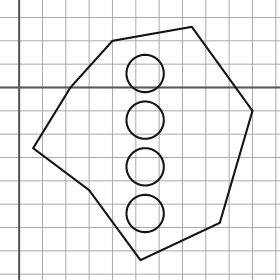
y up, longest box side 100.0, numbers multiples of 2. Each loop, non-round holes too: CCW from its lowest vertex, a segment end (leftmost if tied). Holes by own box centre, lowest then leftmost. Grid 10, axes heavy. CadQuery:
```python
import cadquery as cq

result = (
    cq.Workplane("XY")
    .moveTo(52.0, -74.0)
    .lineTo(86.0, -58.0)
    .lineTo(100.0, -10.0)
    .lineTo(74.0, 26.0)
    .lineTo(40.0, 20.0)
    .lineTo(22.0, 0.0)
    .lineTo(6.0, -26.0)
    .lineTo(30.0, -44.0)
    .close()
    .moveTo(54.0, -54.0)
    .circle(8.0)
    .moveTo(54.0, -34.0)
    .circle(8.0)
    .moveTo(54.0, -14.0)
    .circle(8.0)
    .moveTo(54.0, 6.0)
    .circle(8.0)
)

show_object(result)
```